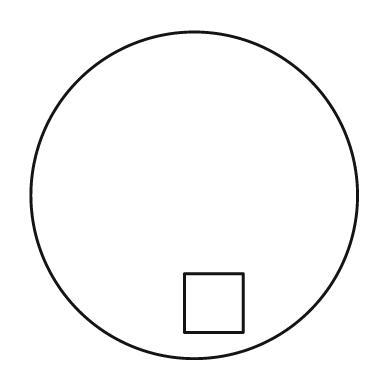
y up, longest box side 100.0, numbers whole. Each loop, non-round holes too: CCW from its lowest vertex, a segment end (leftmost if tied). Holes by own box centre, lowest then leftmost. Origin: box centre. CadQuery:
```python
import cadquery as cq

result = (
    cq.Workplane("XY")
    .moveTo(0.0, 0.0)
    .circle(50.0)
    .moveTo(-3.0, -42.0)
    .lineTo(15.0, -42.0)
    .lineTo(15.0, -24.0)
    .lineTo(-3.0, -24.0)
    .close()
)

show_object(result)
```